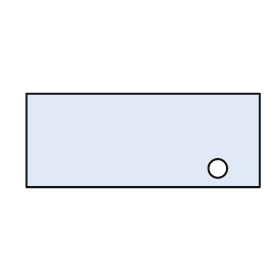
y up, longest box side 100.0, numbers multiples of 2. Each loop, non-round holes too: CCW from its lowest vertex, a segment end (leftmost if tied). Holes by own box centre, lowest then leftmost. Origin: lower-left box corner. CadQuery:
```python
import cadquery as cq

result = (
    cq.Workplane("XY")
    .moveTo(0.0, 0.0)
    .lineTo(100.0, 0.0)
    .lineTo(100.0, 40.0)
    .lineTo(0.0, 40.0)
    .close()
    .moveTo(82.0, 8.0)
    .circle(4.0)
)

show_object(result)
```